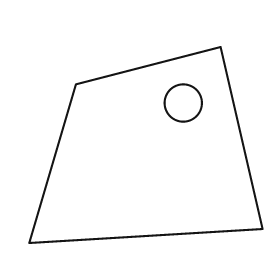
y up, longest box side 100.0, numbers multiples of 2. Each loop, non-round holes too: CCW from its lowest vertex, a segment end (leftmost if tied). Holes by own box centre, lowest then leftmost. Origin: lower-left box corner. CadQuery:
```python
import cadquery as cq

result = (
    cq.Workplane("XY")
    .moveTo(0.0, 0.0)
    .lineTo(100.0, 6.0)
    .lineTo(82.0, 84.0)
    .lineTo(20.0, 68.0)
    .close()
    .moveTo(66.0, 60.0)
    .circle(8.0)
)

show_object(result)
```